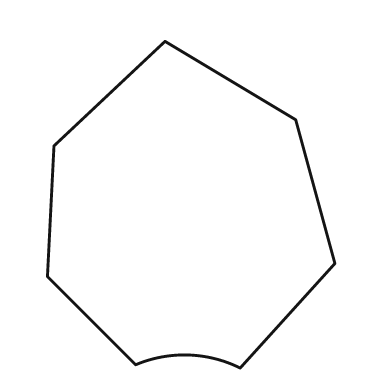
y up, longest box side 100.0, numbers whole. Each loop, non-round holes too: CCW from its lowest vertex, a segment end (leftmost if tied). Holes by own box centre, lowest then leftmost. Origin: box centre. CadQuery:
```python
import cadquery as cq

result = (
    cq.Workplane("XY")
    .moveTo(15.0, -50.0)
    .lineTo(44.0, -18.0)
    .lineTo(32.0, 26.0)
    .lineTo(-8.0, 50.0)
    .lineTo(-42.0, 18.0)
    .lineTo(-44.0, -22.0)
    .lineTo(-17.0, -49.0)
    .threePointArc((-1.0, -46.0), (15.0, -50.0))
    .close()
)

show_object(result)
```